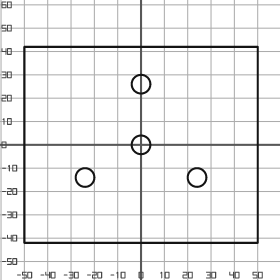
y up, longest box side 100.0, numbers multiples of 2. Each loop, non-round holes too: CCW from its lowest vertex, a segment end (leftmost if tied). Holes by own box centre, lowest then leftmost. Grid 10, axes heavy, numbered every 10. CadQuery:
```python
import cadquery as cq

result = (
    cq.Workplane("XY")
    .moveTo(-50.0, -42.0)
    .lineTo(50.0, -42.0)
    .lineTo(50.0, 42.0)
    .lineTo(-50.0, 42.0)
    .close()
    .moveTo(-24.0, -14.0)
    .circle(4.0)
    .moveTo(24.0, -14.0)
    .circle(4.0)
    .moveTo(0.0, 0.0)
    .circle(4.0)
    .moveTo(0.0, 26.0)
    .circle(4.0)
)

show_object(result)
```